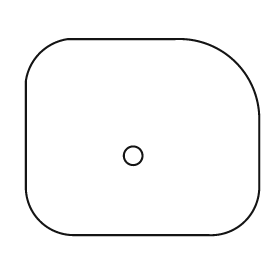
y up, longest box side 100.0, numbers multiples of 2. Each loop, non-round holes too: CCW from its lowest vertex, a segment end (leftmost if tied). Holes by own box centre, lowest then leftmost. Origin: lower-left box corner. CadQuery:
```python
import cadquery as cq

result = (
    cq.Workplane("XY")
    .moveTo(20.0, 0.0)
    .lineTo(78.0, 0.0)
    .threePointArc((94.0, 6.0), (100.0, 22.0))
    .lineTo(100.0, 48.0)
    .threePointArc((90.0, 74.0), (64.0, 84.0))
    .lineTo(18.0, 84.0)
    .threePointArc((6.0, 78.0), (0.0, 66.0))
    .lineTo(0.0, 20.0)
    .threePointArc((6.0, 6.0), (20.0, 0.0))
    .close()
    .moveTo(46.0, 34.0)
    .circle(4.0)
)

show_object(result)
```